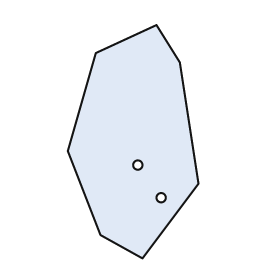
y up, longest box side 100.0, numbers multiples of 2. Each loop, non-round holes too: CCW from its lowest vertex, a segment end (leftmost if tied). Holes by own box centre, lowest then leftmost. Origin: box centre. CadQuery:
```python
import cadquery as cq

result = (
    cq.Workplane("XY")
    .moveTo(4.0, -50.0)
    .lineTo(28.0, -18.0)
    .lineTo(20.0, 34.0)
    .lineTo(10.0, 50.0)
    .lineTo(-16.0, 38.0)
    .lineTo(-28.0, -4.0)
    .lineTo(-14.0, -40.0)
    .close()
    .moveTo(12.0, -24.0)
    .circle(2.0)
    .moveTo(2.0, -10.0)
    .circle(2.0)
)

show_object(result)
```